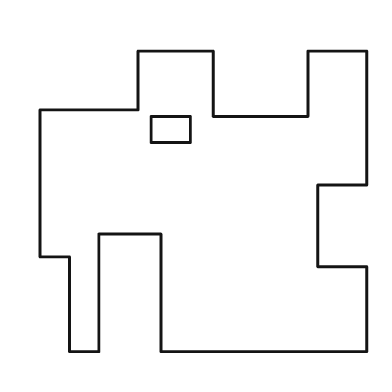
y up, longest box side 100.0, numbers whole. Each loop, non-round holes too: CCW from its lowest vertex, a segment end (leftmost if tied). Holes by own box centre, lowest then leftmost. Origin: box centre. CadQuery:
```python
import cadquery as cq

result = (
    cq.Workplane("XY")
    .moveTo(-41.0, -46.0)
    .lineTo(-32.0, -46.0)
    .lineTo(-32.0, -10.0)
    .lineTo(-13.0, -10.0)
    .lineTo(-13.0, -46.0)
    .lineTo(50.0, -46.0)
    .lineTo(50.0, -20.0)
    .lineTo(35.0, -20.0)
    .lineTo(35.0, 5.0)
    .lineTo(50.0, 5.0)
    .lineTo(50.0, 46.0)
    .lineTo(32.0, 46.0)
    .lineTo(32.0, 26.0)
    .lineTo(3.0, 26.0)
    .lineTo(3.0, 46.0)
    .lineTo(-20.0, 46.0)
    .lineTo(-20.0, 28.0)
    .lineTo(-50.0, 28.0)
    .lineTo(-50.0, -17.0)
    .lineTo(-41.0, -17.0)
    .close()
    .moveTo(-16.0, 18.0)
    .lineTo(-4.0, 18.0)
    .lineTo(-4.0, 26.0)
    .lineTo(-16.0, 26.0)
    .close()
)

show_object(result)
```